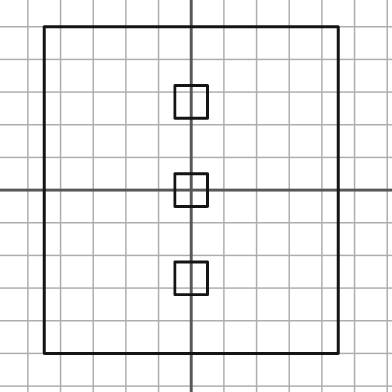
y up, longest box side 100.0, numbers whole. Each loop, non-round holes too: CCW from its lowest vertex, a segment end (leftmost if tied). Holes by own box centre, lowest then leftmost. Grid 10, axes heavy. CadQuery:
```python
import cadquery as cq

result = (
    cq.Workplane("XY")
    .moveTo(-45.0, -50.0)
    .lineTo(45.0, -50.0)
    .lineTo(45.0, 50.0)
    .lineTo(-45.0, 50.0)
    .close()
    .moveTo(-5.0, -32.0)
    .lineTo(5.0, -32.0)
    .lineTo(5.0, -22.0)
    .lineTo(-5.0, -22.0)
    .close()
    .moveTo(-5.0, -5.0)
    .lineTo(5.0, -5.0)
    .lineTo(5.0, 5.0)
    .lineTo(-5.0, 5.0)
    .close()
    .moveTo(-5.0, 22.0)
    .lineTo(5.0, 22.0)
    .lineTo(5.0, 32.0)
    .lineTo(-5.0, 32.0)
    .close()
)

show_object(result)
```